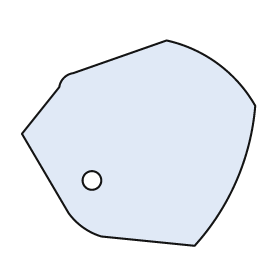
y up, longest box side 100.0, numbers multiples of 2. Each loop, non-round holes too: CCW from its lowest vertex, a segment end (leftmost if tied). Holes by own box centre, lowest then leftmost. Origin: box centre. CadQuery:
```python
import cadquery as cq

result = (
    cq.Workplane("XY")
    .moveTo(24.0, -44.0)
    .threePointArc((42.0, -16.0), (50.0, 16.0))
    .threePointArc((34.0, 34.0), (12.0, 44.0))
    .lineTo(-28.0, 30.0)
    .threePointArc((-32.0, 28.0), (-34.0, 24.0))
    .lineTo(-50.0, 4.0)
    .lineTo(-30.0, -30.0)
    .threePointArc((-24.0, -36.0), (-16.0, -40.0))
    .close()
    .moveTo(-20.0, -16.0)
    .circle(4.0)
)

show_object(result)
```